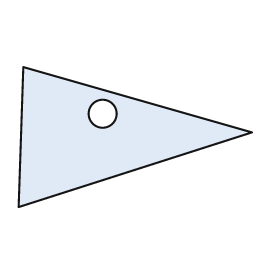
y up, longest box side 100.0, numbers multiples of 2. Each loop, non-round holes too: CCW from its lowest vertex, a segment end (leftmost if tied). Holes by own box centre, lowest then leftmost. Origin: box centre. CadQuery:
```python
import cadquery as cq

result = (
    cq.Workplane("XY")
    .moveTo(-50.0, -30.0)
    .lineTo(50.0, 2.0)
    .lineTo(-48.0, 30.0)
    .close()
    .moveTo(-14.0, 10.0)
    .circle(6.0)
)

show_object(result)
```